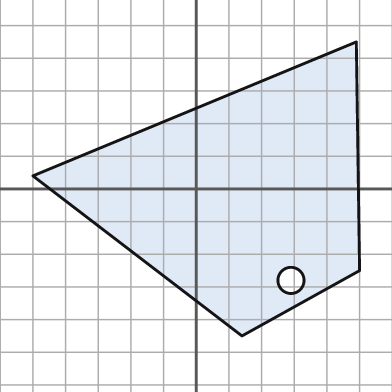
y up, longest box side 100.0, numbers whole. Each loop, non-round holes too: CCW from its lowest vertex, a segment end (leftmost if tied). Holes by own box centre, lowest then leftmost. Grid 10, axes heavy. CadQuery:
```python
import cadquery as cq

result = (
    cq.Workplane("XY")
    .moveTo(14.0, -45.0)
    .lineTo(50.0, -25.0)
    .lineTo(49.0, 45.0)
    .lineTo(-50.0, 4.0)
    .close()
    .moveTo(29.0, -28.0)
    .circle(4.0)
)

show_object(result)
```